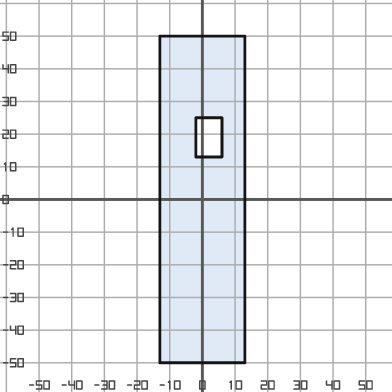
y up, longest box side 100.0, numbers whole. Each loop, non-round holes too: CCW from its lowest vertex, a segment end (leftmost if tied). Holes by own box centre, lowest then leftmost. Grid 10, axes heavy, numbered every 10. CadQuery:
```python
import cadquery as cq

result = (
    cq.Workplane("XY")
    .moveTo(-13.0, -50.0)
    .lineTo(13.0, -50.0)
    .lineTo(13.0, 50.0)
    .lineTo(-13.0, 50.0)
    .close()
    .moveTo(-2.0, 13.0)
    .lineTo(6.0, 13.0)
    .lineTo(6.0, 25.0)
    .lineTo(-2.0, 25.0)
    .close()
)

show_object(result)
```